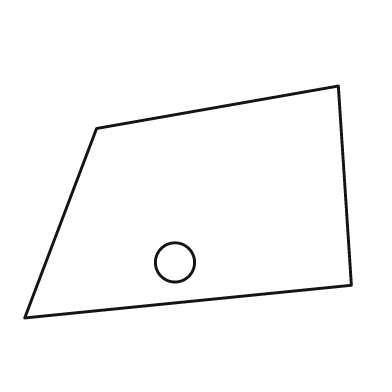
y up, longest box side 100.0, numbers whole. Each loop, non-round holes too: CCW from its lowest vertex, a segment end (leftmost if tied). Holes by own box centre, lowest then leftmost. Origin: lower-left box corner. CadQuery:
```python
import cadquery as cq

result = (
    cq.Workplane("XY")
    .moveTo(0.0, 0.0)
    .lineTo(100.0, 10.0)
    .lineTo(96.0, 71.0)
    .lineTo(22.0, 58.0)
    .close()
    .moveTo(46.0, 17.0)
    .circle(6.0)
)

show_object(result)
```